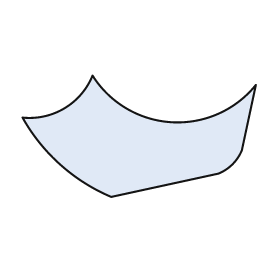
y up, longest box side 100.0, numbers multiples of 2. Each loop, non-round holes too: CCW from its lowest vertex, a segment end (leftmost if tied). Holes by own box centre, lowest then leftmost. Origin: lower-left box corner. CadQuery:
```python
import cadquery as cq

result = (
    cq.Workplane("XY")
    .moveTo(38.0, 0.0)
    .lineTo(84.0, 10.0)
    .threePointArc((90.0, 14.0), (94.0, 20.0))
    .lineTo(100.0, 48.0)
    .threePointArc((64.0, 32.0), (30.0, 52.0))
    .threePointArc((18.0, 38.0), (0.0, 34.0))
    .threePointArc((16.0, 14.0), (38.0, 0.0))
    .close()
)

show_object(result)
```